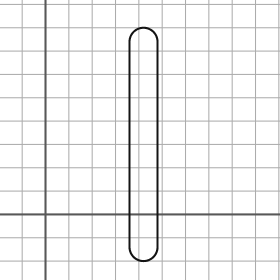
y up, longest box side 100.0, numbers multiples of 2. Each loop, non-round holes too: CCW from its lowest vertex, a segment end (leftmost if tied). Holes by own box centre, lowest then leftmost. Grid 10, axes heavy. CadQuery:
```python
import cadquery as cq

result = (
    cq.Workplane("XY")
    .moveTo(36.0, -14.0)
    .threePointArc((42.0, -20.0), (48.0, -14.0))
    .lineTo(48.0, 74.0)
    .threePointArc((42.0, 80.0), (36.0, 74.0))
    .close()
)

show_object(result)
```